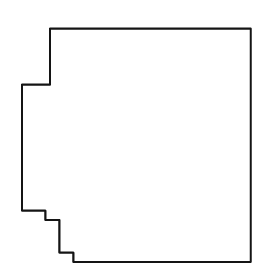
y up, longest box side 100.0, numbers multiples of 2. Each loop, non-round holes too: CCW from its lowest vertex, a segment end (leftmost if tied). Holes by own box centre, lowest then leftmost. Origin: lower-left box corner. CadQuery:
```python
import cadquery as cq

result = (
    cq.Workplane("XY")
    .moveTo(22.0, 0.0)
    .lineTo(98.0, 0.0)
    .lineTo(98.0, 100.0)
    .lineTo(12.0, 100.0)
    .lineTo(12.0, 76.0)
    .lineTo(0.0, 76.0)
    .lineTo(0.0, 22.0)
    .lineTo(10.0, 22.0)
    .lineTo(10.0, 18.0)
    .lineTo(16.0, 18.0)
    .lineTo(16.0, 4.0)
    .lineTo(22.0, 4.0)
    .close()
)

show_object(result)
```